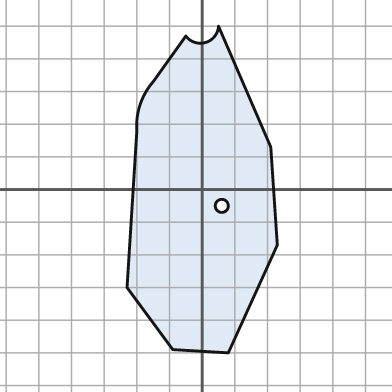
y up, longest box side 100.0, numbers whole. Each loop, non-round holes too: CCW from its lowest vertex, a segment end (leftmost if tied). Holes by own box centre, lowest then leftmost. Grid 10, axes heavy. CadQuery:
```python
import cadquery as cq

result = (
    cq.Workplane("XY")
    .moveTo(8.0, -50.0)
    .lineTo(23.0, -17.0)
    .lineTo(21.0, 13.0)
    .lineTo(5.0, 50.0)
    .threePointArc((1.0, 45.0), (-5.0, 47.0))
    .lineTo(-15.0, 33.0)
    .threePointArc((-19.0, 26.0), (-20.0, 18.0))
    .lineTo(-23.0, -30.0)
    .lineTo(-9.0, -49.0)
    .close()
    .moveTo(6.0, -5.0)
    .circle(2.0)
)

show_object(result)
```